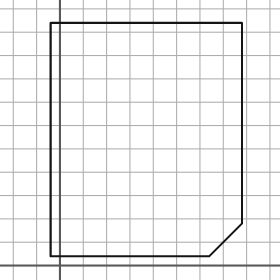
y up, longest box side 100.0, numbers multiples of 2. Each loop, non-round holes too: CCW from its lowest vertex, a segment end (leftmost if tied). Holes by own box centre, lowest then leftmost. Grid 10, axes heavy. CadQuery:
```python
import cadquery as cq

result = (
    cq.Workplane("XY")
    .moveTo(-4.0, 4.0)
    .lineTo(64.0, 4.0)
    .lineTo(78.0, 18.0)
    .lineTo(78.0, 104.0)
    .lineTo(-4.0, 104.0)
    .close()
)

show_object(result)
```